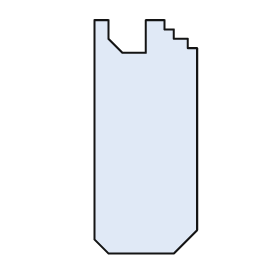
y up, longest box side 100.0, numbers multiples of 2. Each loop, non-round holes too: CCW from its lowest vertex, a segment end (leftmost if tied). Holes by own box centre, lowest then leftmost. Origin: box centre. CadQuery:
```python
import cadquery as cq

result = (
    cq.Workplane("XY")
    .moveTo(-16.0, -50.0)
    .lineTo(12.0, -50.0)
    .lineTo(22.0, -40.0)
    .lineTo(22.0, 38.0)
    .lineTo(18.0, 38.0)
    .lineTo(18.0, 42.0)
    .lineTo(12.0, 42.0)
    .lineTo(12.0, 46.0)
    .lineTo(8.0, 46.0)
    .lineTo(8.0, 50.0)
    .lineTo(0.0, 50.0)
    .lineTo(0.0, 36.0)
    .lineTo(-10.0, 36.0)
    .lineTo(-16.0, 42.0)
    .lineTo(-16.0, 50.0)
    .lineTo(-22.0, 50.0)
    .lineTo(-22.0, -44.0)
    .close()
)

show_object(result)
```